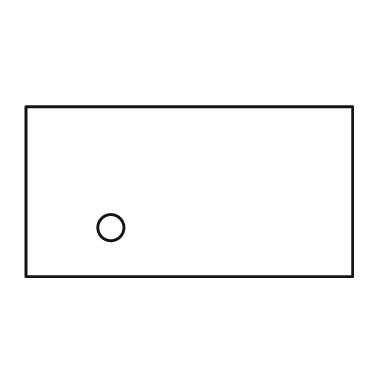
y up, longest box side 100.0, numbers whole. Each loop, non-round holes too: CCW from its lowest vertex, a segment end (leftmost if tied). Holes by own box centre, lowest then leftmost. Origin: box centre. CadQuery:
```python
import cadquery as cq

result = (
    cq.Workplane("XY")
    .moveTo(-50.0, -26.0)
    .lineTo(50.0, -26.0)
    .lineTo(50.0, 26.0)
    .lineTo(-50.0, 26.0)
    .close()
    .moveTo(-24.0, -11.0)
    .circle(4.0)
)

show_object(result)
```